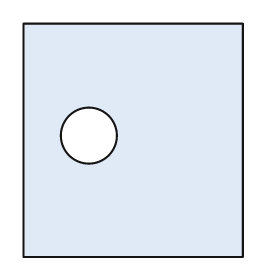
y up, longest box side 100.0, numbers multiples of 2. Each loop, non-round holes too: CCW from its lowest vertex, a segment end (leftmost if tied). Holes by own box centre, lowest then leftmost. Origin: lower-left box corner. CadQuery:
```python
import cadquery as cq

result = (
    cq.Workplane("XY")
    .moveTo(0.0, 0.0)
    .lineTo(94.0, 0.0)
    .lineTo(94.0, 100.0)
    .lineTo(0.0, 100.0)
    .close()
    .moveTo(28.0, 52.0)
    .circle(12.0)
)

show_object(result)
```